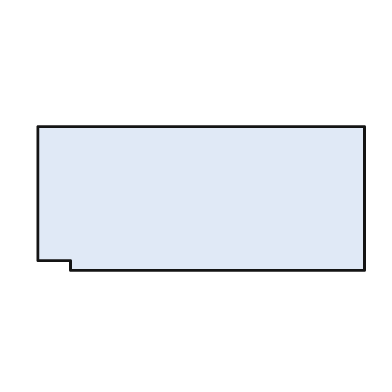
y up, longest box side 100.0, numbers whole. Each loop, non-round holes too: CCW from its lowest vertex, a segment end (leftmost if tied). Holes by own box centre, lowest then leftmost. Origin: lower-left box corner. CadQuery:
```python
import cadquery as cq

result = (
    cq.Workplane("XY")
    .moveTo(10.0, 0.0)
    .lineTo(100.0, 0.0)
    .lineTo(100.0, 44.0)
    .lineTo(0.0, 44.0)
    .lineTo(0.0, 3.0)
    .lineTo(10.0, 3.0)
    .close()
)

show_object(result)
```